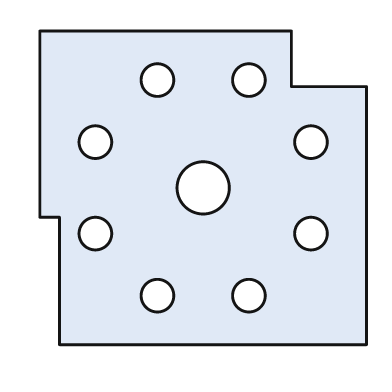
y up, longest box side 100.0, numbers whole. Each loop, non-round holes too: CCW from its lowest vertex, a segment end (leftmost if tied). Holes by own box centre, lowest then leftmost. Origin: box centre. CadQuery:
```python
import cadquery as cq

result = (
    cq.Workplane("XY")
    .moveTo(-44.0, -48.0)
    .lineTo(50.0, -48.0)
    .lineTo(50.0, 31.0)
    .lineTo(27.0, 31.0)
    .lineTo(27.0, 48.0)
    .lineTo(-50.0, 48.0)
    .lineTo(-50.0, -9.0)
    .lineTo(-44.0, -9.0)
    .close()
    .moveTo(-14.0, -33.0)
    .circle(5.0)
    .moveTo(14.0, -33.0)
    .circle(5.0)
    .moveTo(-33.0, -14.0)
    .circle(5.0)
    .moveTo(33.0, -14.0)
    .circle(5.0)
    .moveTo(0.0, 0.0)
    .circle(8.0)
    .moveTo(-33.0, 14.0)
    .circle(5.0)
    .moveTo(33.0, 14.0)
    .circle(5.0)
    .moveTo(-14.0, 33.0)
    .circle(5.0)
    .moveTo(14.0, 33.0)
    .circle(5.0)
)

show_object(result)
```